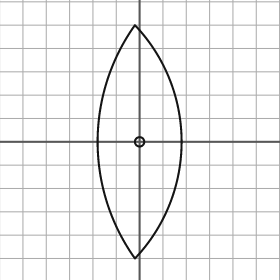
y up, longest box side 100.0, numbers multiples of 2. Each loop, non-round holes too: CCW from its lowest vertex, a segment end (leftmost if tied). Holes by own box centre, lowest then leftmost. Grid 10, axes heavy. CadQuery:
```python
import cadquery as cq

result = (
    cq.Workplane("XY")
    .moveTo(-2.0, -50.0)
    .threePointArc((18.0, 0.0), (-2.0, 50.0))
    .threePointArc((-18.0, 0.0), (-2.0, -50.0))
    .close()
    .moveTo(0.0, 0.0)
    .circle(2.0)
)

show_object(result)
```